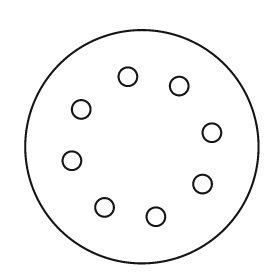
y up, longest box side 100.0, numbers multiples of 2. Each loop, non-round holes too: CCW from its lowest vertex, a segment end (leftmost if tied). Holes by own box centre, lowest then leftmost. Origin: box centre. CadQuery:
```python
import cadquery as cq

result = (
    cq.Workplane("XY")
    .moveTo(0.0, 0.0)
    .circle(50.0)
    .moveTo(6.0, -30.0)
    .circle(4.0)
    .moveTo(-16.0, -26.0)
    .circle(4.0)
    .moveTo(26.0, -16.0)
    .circle(4.0)
    .moveTo(-30.0, -6.0)
    .circle(4.0)
    .moveTo(30.0, 6.0)
    .circle(4.0)
    .moveTo(-26.0, 16.0)
    .circle(4.0)
    .moveTo(16.0, 26.0)
    .circle(4.0)
    .moveTo(-6.0, 30.0)
    .circle(4.0)
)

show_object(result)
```